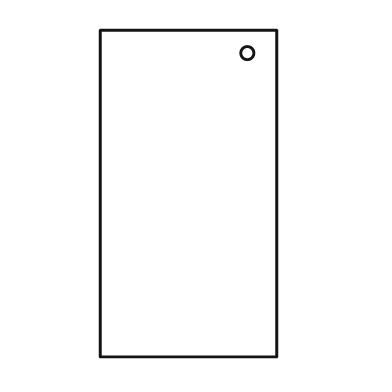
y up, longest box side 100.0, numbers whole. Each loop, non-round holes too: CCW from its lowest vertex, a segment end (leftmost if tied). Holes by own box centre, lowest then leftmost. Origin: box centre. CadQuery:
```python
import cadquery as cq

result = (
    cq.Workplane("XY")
    .moveTo(-27.0, -50.0)
    .lineTo(27.0, -50.0)
    .lineTo(27.0, 50.0)
    .lineTo(-27.0, 50.0)
    .close()
    .moveTo(18.0, 43.0)
    .circle(2.0)
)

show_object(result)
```